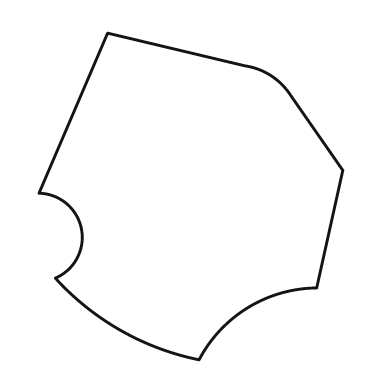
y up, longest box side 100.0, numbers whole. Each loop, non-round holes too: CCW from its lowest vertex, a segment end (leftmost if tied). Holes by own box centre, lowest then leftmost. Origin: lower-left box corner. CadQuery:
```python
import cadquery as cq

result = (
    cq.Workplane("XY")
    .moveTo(49.0, 0.0)
    .threePointArc((64.0, 16.0), (85.0, 22.0))
    .lineTo(93.0, 58.0)
    .lineTo(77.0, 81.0)
    .threePointArc((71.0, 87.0), (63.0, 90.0))
    .lineTo(21.0, 100.0)
    .lineTo(0.0, 51.0)
    .threePointArc((13.0, 40.0), (5.0, 25.0))
    .threePointArc((25.0, 9.0), (49.0, 0.0))
    .close()
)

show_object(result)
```